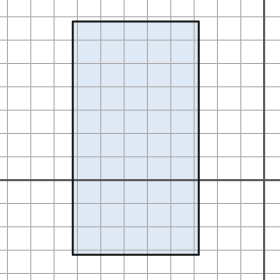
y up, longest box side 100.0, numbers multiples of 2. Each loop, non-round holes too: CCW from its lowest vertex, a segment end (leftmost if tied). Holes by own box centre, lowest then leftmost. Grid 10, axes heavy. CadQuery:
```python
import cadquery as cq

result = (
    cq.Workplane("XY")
    .moveTo(-82.0, -32.0)
    .lineTo(-28.0, -32.0)
    .lineTo(-28.0, 68.0)
    .lineTo(-82.0, 68.0)
    .close()
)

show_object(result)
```